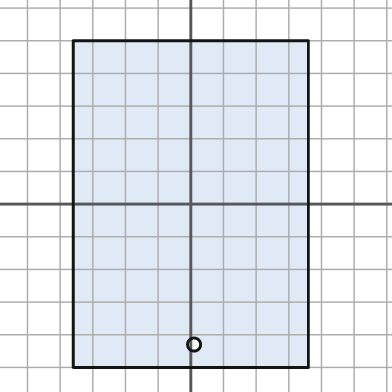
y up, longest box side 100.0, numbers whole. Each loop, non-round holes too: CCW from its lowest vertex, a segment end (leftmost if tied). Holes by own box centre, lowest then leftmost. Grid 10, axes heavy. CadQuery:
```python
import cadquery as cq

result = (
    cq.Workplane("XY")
    .moveTo(-36.0, -50.0)
    .lineTo(36.0, -50.0)
    .lineTo(36.0, 50.0)
    .lineTo(-36.0, 50.0)
    .close()
    .moveTo(1.0, -43.0)
    .circle(2.0)
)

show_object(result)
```